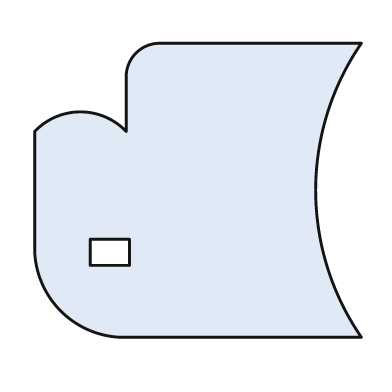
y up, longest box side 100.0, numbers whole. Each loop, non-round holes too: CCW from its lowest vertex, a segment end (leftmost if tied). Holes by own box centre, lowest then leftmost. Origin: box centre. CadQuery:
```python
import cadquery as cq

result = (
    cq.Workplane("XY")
    .moveTo(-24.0, -45.0)
    .lineTo(50.0, -45.0)
    .threePointArc((36.0, 0.0), (50.0, 45.0))
    .lineTo(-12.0, 45.0)
    .threePointArc((-19.0, 42.0), (-22.0, 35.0))
    .lineTo(-22.0, 18.0)
    .threePointArc((-36.0, 24.0), (-50.0, 18.0))
    .lineTo(-50.0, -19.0)
    .threePointArc((-42.0, -37.0), (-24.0, -45.0))
    .close()
    .moveTo(-33.0, -23.0)
    .lineTo(-21.0, -23.0)
    .lineTo(-21.0, -15.0)
    .lineTo(-33.0, -15.0)
    .close()
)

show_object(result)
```